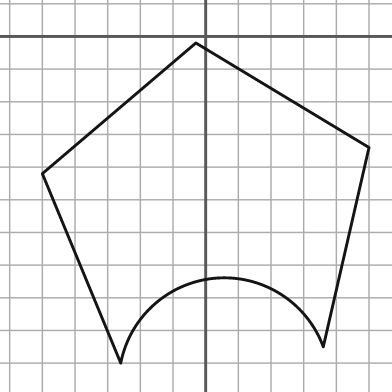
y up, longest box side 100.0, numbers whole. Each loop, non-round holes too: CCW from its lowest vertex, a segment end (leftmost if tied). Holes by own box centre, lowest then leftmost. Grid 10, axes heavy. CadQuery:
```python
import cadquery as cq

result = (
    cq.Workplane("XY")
    .moveTo(-26.0, -100.0)
    .threePointArc((3.0, -74.0), (36.0, -95.0))
    .lineTo(50.0, -34.0)
    .lineTo(-3.0, -2.0)
    .lineTo(-50.0, -42.0)
    .close()
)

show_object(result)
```